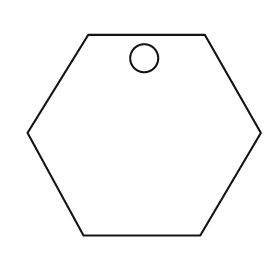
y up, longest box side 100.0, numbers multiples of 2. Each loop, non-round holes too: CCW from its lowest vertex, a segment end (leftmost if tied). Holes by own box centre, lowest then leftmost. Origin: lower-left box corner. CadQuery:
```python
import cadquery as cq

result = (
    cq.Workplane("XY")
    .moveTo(24.0, 0.0)
    .lineTo(74.0, 0.0)
    .lineTo(100.0, 44.0)
    .lineTo(76.0, 86.0)
    .lineTo(26.0, 86.0)
    .lineTo(0.0, 44.0)
    .close()
    .moveTo(50.0, 76.0)
    .circle(6.0)
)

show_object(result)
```